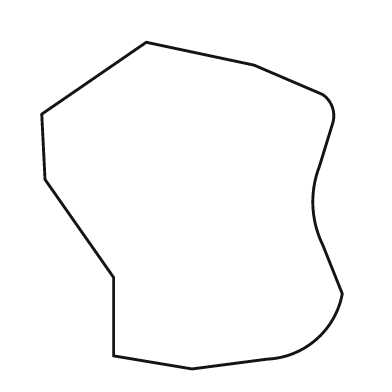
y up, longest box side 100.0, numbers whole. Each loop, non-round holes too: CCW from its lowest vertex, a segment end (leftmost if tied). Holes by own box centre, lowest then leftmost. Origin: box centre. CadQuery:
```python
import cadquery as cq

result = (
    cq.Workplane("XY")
    .moveTo(0.0, -50.0)
    .lineTo(23.0, -47.0)
    .threePointArc((38.0, -41.0), (46.0, -27.0))
    .lineTo(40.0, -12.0)
    .threePointArc((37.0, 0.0), (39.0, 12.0))
    .lineTo(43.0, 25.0)
    .threePointArc((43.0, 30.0), (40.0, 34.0))
    .lineTo(19.0, 43.0)
    .lineTo(-14.0, 50.0)
    .lineTo(-46.0, 28.0)
    .lineTo(-45.0, 8.0)
    .lineTo(-24.0, -22.0)
    .lineTo(-24.0, -46.0)
    .close()
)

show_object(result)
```